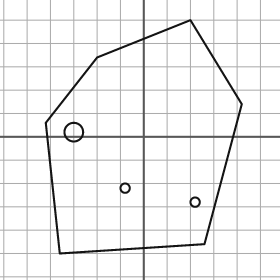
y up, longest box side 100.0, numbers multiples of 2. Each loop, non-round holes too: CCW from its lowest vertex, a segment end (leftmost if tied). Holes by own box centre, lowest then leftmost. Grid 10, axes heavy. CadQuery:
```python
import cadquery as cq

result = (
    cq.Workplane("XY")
    .moveTo(-36.0, -50.0)
    .lineTo(26.0, -46.0)
    .lineTo(42.0, 14.0)
    .lineTo(20.0, 50.0)
    .lineTo(-20.0, 34.0)
    .lineTo(-42.0, 6.0)
    .close()
    .moveTo(22.0, -28.0)
    .circle(2.0)
    .moveTo(-8.0, -22.0)
    .circle(2.0)
    .moveTo(-30.0, 2.0)
    .circle(4.0)
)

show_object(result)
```